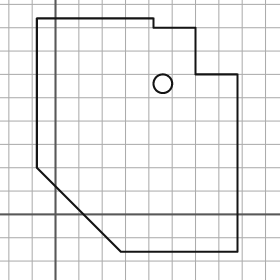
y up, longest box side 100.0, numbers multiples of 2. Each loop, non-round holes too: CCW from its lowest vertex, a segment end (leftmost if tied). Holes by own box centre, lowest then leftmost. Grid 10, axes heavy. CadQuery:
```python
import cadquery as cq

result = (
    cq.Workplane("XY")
    .moveTo(28.0, -16.0)
    .lineTo(78.0, -16.0)
    .lineTo(78.0, 60.0)
    .lineTo(60.0, 60.0)
    .lineTo(60.0, 80.0)
    .lineTo(42.0, 80.0)
    .lineTo(42.0, 84.0)
    .lineTo(-8.0, 84.0)
    .lineTo(-8.0, 20.0)
    .close()
    .moveTo(46.0, 56.0)
    .circle(4.0)
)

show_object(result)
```